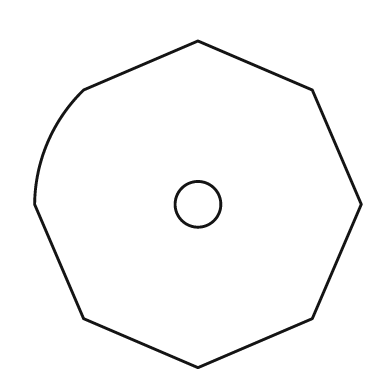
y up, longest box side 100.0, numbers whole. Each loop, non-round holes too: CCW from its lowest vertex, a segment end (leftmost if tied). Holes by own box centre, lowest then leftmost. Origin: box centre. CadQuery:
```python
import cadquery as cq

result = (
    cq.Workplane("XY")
    .moveTo(0.0, -50.0)
    .lineTo(35.0, -35.0)
    .lineTo(50.0, 0.0)
    .lineTo(35.0, 35.0)
    .lineTo(0.0, 50.0)
    .lineTo(-35.0, 35.0)
    .threePointArc((-46.0, 19.0), (-50.0, 0.0))
    .lineTo(-35.0, -35.0)
    .close()
    .moveTo(0.0, 0.0)
    .circle(7.0)
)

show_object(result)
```